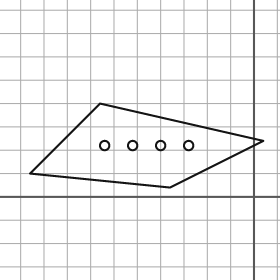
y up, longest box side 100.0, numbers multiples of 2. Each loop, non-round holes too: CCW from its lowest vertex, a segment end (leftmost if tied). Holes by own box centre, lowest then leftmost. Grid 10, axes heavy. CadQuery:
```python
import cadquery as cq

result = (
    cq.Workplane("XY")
    .moveTo(-36.0, 4.0)
    .lineTo(4.0, 24.0)
    .lineTo(-66.0, 40.0)
    .lineTo(-96.0, 10.0)
    .close()
    .moveTo(-64.0, 22.0)
    .circle(2.0)
    .moveTo(-52.0, 22.0)
    .circle(2.0)
    .moveTo(-40.0, 22.0)
    .circle(2.0)
    .moveTo(-28.0, 22.0)
    .circle(2.0)
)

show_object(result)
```